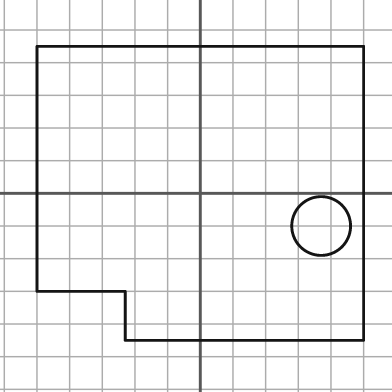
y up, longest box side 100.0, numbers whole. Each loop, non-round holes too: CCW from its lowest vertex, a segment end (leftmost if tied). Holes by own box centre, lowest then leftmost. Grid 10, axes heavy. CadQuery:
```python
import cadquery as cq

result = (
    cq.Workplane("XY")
    .moveTo(-23.0, -45.0)
    .lineTo(50.0, -45.0)
    .lineTo(50.0, 45.0)
    .lineTo(-50.0, 45.0)
    .lineTo(-50.0, -30.0)
    .lineTo(-23.0, -30.0)
    .close()
    .moveTo(37.0, -10.0)
    .circle(9.0)
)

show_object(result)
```